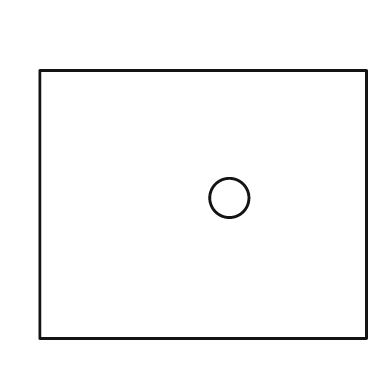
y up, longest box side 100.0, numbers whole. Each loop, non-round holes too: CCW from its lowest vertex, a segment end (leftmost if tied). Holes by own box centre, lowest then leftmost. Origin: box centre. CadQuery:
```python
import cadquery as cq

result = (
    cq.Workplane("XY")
    .moveTo(-50.0, -41.0)
    .lineTo(50.0, -41.0)
    .lineTo(50.0, 41.0)
    .lineTo(-50.0, 41.0)
    .close()
    .moveTo(8.0, 2.0)
    .circle(6.0)
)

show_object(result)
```